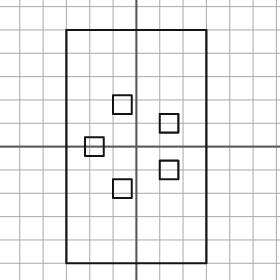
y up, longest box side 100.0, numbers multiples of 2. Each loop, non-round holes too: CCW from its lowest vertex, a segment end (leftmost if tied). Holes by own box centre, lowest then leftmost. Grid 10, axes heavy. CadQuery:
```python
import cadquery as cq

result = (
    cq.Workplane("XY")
    .moveTo(-30.0, -50.0)
    .lineTo(30.0, -50.0)
    .lineTo(30.0, 50.0)
    .lineTo(-30.0, 50.0)
    .close()
    .moveTo(-10.0, -22.0)
    .lineTo(-2.0, -22.0)
    .lineTo(-2.0, -14.0)
    .lineTo(-10.0, -14.0)
    .close()
    .moveTo(10.0, -14.0)
    .lineTo(18.0, -14.0)
    .lineTo(18.0, -6.0)
    .lineTo(10.0, -6.0)
    .close()
    .moveTo(-22.0, -4.0)
    .lineTo(-14.0, -4.0)
    .lineTo(-14.0, 4.0)
    .lineTo(-22.0, 4.0)
    .close()
    .moveTo(10.0, 6.0)
    .lineTo(18.0, 6.0)
    .lineTo(18.0, 14.0)
    .lineTo(10.0, 14.0)
    .close()
    .moveTo(-10.0, 14.0)
    .lineTo(-2.0, 14.0)
    .lineTo(-2.0, 22.0)
    .lineTo(-10.0, 22.0)
    .close()
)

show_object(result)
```